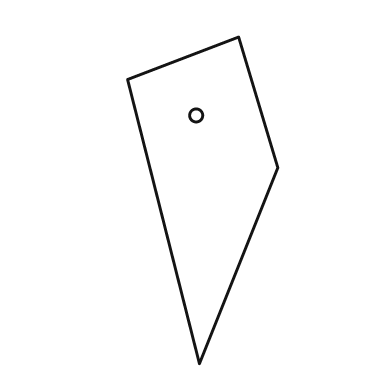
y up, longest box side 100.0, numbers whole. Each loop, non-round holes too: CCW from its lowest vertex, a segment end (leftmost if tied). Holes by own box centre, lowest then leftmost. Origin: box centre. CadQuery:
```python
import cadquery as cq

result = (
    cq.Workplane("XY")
    .moveTo(-1.0, -50.0)
    .lineTo(23.0, 10.0)
    .lineTo(11.0, 50.0)
    .lineTo(-23.0, 37.0)
    .close()
    .moveTo(-2.0, 26.0)
    .circle(2.0)
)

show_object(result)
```